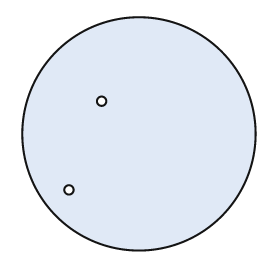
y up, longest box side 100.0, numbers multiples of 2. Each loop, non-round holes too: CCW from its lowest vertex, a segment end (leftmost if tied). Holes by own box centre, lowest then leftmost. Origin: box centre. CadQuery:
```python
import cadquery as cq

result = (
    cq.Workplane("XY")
    .moveTo(0.0, 0.0)
    .circle(50.0)
    .moveTo(-30.0, -24.0)
    .circle(2.0)
    .moveTo(-16.0, 14.0)
    .circle(2.0)
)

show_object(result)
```